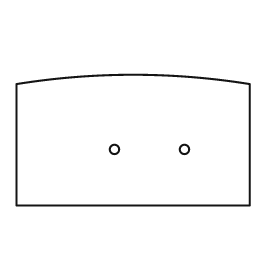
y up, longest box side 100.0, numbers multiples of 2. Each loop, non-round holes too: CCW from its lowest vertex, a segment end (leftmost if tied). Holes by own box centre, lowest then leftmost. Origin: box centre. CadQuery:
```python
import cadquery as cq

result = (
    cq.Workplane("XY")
    .moveTo(-50.0, -28.0)
    .lineTo(50.0, -28.0)
    .lineTo(50.0, 24.0)
    .threePointArc((0.0, 28.0), (-50.0, 24.0))
    .close()
    .moveTo(-8.0, -4.0)
    .circle(2.0)
    .moveTo(22.0, -4.0)
    .circle(2.0)
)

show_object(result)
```